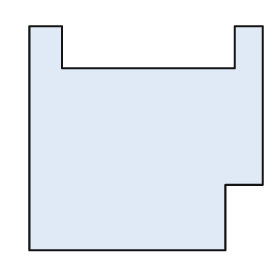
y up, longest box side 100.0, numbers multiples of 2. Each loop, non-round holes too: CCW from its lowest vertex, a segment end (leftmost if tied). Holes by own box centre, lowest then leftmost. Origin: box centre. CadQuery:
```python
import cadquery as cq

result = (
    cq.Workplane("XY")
    .moveTo(-50.0, -48.0)
    .lineTo(34.0, -48.0)
    .lineTo(34.0, -20.0)
    .lineTo(50.0, -20.0)
    .lineTo(50.0, 48.0)
    .lineTo(38.0, 48.0)
    .lineTo(38.0, 30.0)
    .lineTo(-36.0, 30.0)
    .lineTo(-36.0, 48.0)
    .lineTo(-50.0, 48.0)
    .close()
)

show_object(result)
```